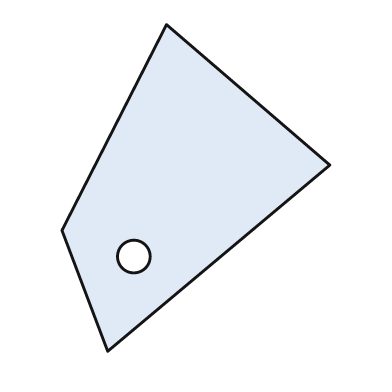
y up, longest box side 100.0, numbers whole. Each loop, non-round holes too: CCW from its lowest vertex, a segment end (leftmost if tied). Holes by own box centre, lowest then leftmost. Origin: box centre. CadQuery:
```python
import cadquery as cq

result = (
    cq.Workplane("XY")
    .moveTo(-27.0, -50.0)
    .lineTo(41.0, 7.0)
    .lineTo(-9.0, 50.0)
    .lineTo(-41.0, -13.0)
    .close()
    .moveTo(-19.0, -21.0)
    .circle(5.0)
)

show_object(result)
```